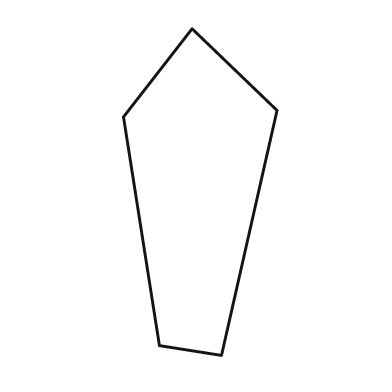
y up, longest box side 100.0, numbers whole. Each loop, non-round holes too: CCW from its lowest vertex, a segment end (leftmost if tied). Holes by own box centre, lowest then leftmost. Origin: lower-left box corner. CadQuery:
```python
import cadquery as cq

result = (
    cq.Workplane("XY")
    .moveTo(30.0, 0.0)
    .lineTo(47.0, 75.0)
    .lineTo(21.0, 100.0)
    .lineTo(0.0, 73.0)
    .lineTo(11.0, 3.0)
    .close()
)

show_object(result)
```